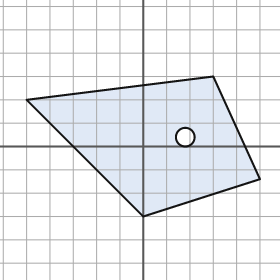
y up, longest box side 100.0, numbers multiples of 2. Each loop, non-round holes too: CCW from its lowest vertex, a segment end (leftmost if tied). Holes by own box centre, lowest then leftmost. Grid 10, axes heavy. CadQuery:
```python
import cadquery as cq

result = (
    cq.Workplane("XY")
    .moveTo(0.0, -30.0)
    .lineTo(50.0, -14.0)
    .lineTo(30.0, 30.0)
    .lineTo(-50.0, 20.0)
    .close()
    .moveTo(18.0, 4.0)
    .circle(4.0)
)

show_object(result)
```